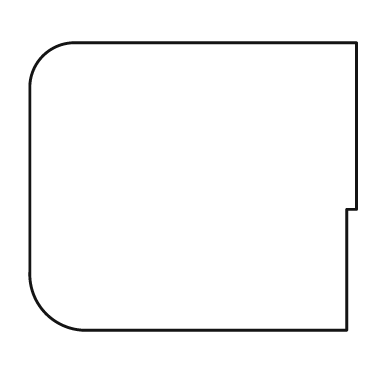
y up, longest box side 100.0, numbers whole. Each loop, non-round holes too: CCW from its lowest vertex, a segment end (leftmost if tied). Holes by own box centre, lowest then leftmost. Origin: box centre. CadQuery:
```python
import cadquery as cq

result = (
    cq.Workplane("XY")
    .moveTo(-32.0, -44.0)
    .lineTo(47.0, -44.0)
    .lineTo(47.0, -7.0)
    .lineTo(50.0, -7.0)
    .lineTo(50.0, 44.0)
    .lineTo(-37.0, 44.0)
    .threePointArc((-46.0, 40.0), (-50.0, 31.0))
    .lineTo(-50.0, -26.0)
    .threePointArc((-45.0, -39.0), (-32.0, -44.0))
    .close()
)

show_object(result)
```